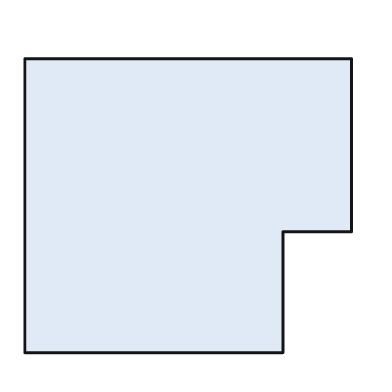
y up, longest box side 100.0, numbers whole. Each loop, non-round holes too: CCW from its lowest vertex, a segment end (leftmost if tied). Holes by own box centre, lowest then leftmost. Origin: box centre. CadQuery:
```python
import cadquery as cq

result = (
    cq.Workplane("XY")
    .moveTo(-50.0, -45.0)
    .lineTo(29.0, -45.0)
    .lineTo(29.0, -8.0)
    .lineTo(50.0, -8.0)
    .lineTo(50.0, 45.0)
    .lineTo(-50.0, 45.0)
    .close()
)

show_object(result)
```